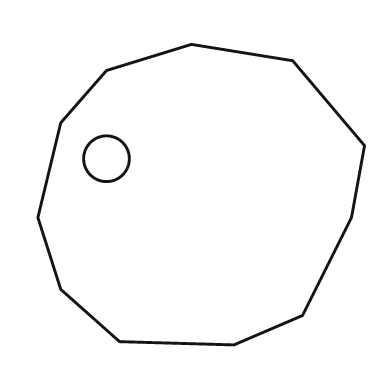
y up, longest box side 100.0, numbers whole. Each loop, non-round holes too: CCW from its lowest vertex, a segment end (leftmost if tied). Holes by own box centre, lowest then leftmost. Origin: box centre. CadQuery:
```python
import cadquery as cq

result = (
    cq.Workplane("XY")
    .moveTo(10.0, -46.0)
    .lineTo(31.0, -37.0)
    .lineTo(46.0, -7.0)
    .lineTo(50.0, 15.0)
    .lineTo(28.0, 41.0)
    .lineTo(-3.0, 46.0)
    .lineTo(-29.0, 38.0)
    .lineTo(-43.0, 22.0)
    .lineTo(-50.0, -7.0)
    .lineTo(-43.0, -29.0)
    .lineTo(-25.0, -45.0)
    .close()
    .moveTo(-29.0, 11.0)
    .circle(7.0)
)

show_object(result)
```